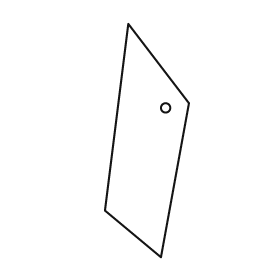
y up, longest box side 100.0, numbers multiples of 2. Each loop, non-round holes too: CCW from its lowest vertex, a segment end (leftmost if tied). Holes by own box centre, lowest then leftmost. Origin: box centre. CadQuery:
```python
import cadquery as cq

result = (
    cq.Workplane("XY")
    .moveTo(6.0, -50.0)
    .lineTo(18.0, 16.0)
    .lineTo(-8.0, 50.0)
    .lineTo(-18.0, -30.0)
    .close()
    .moveTo(8.0, 14.0)
    .circle(2.0)
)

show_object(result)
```